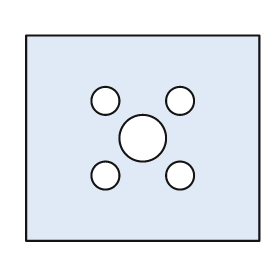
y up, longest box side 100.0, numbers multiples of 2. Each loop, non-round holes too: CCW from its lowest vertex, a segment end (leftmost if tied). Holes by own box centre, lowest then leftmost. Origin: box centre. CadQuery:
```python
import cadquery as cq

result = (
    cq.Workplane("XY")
    .moveTo(-50.0, -44.0)
    .lineTo(50.0, -44.0)
    .lineTo(50.0, 44.0)
    .lineTo(-50.0, 44.0)
    .close()
    .moveTo(-16.0, -16.0)
    .circle(6.0)
    .moveTo(16.0, -16.0)
    .circle(6.0)
    .moveTo(0.0, 0.0)
    .circle(10.0)
    .moveTo(-16.0, 16.0)
    .circle(6.0)
    .moveTo(16.0, 16.0)
    .circle(6.0)
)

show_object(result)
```